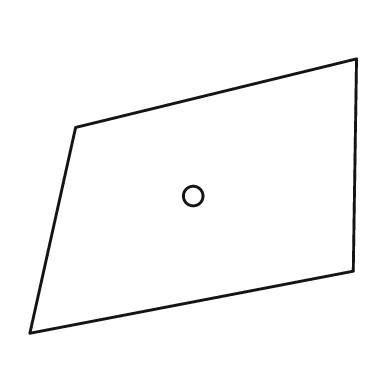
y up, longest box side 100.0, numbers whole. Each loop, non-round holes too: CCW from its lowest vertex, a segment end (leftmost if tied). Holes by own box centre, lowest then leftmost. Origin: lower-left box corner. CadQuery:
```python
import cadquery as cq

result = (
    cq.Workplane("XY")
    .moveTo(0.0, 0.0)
    .lineTo(99.0, 19.0)
    .lineTo(100.0, 84.0)
    .lineTo(14.0, 63.0)
    .close()
    .moveTo(50.0, 42.0)
    .circle(3.0)
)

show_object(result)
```